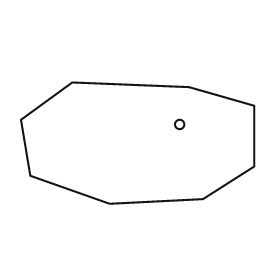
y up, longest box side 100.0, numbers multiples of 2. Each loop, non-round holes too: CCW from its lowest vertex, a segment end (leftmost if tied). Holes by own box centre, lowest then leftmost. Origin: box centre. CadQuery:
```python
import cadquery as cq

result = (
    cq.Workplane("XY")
    .moveTo(-12.0, -26.0)
    .lineTo(28.0, -24.0)
    .lineTo(50.0, -10.0)
    .lineTo(50.0, 16.0)
    .lineTo(22.0, 24.0)
    .lineTo(-28.0, 26.0)
    .lineTo(-50.0, 10.0)
    .lineTo(-46.0, -14.0)
    .close()
    .moveTo(18.0, 8.0)
    .circle(2.0)
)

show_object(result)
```